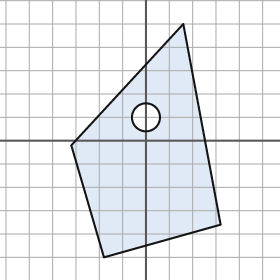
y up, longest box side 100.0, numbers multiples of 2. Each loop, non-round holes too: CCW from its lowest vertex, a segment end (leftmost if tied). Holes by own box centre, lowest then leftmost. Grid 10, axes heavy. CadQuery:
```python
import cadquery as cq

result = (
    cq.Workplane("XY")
    .moveTo(-18.0, -50.0)
    .lineTo(32.0, -36.0)
    .lineTo(16.0, 50.0)
    .lineTo(-32.0, -2.0)
    .close()
    .moveTo(0.0, 10.0)
    .circle(6.0)
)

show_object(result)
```